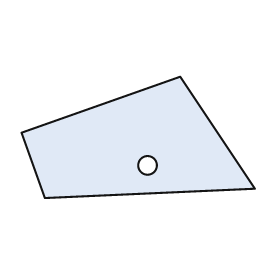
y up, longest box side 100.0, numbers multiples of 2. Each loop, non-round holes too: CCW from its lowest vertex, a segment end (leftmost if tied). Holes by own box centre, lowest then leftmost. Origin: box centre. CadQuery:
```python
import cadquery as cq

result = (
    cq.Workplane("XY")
    .moveTo(-40.0, -26.0)
    .lineTo(50.0, -22.0)
    .lineTo(18.0, 26.0)
    .lineTo(-50.0, 2.0)
    .close()
    .moveTo(4.0, -12.0)
    .circle(4.0)
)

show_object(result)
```